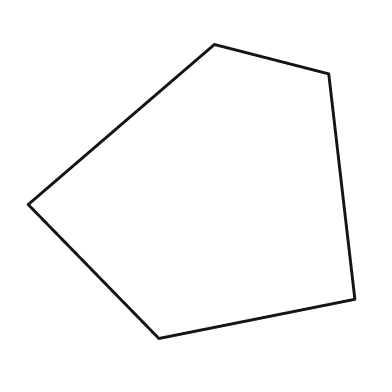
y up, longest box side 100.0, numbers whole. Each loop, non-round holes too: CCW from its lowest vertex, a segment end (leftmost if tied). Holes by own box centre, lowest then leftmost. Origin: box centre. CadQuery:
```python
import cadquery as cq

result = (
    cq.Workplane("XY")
    .moveTo(-10.0, -45.0)
    .lineTo(50.0, -33.0)
    .lineTo(42.0, 36.0)
    .lineTo(7.0, 45.0)
    .lineTo(-50.0, -4.0)
    .close()
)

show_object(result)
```